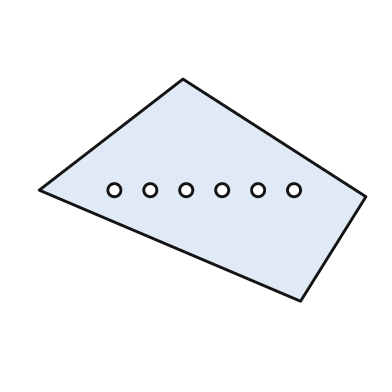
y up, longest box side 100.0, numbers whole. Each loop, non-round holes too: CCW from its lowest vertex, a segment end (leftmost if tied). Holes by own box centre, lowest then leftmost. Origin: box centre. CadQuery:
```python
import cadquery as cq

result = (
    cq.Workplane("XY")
    .moveTo(30.0, -34.0)
    .lineTo(50.0, -2.0)
    .lineTo(-6.0, 34.0)
    .lineTo(-50.0, 0.0)
    .close()
    .moveTo(-27.0, 0.0)
    .circle(2.0)
    .moveTo(-16.0, 0.0)
    .circle(2.0)
    .moveTo(-5.0, 0.0)
    .circle(2.0)
    .moveTo(6.0, 0.0)
    .circle(2.0)
    .moveTo(17.0, 0.0)
    .circle(2.0)
    .moveTo(28.0, 0.0)
    .circle(2.0)
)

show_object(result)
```